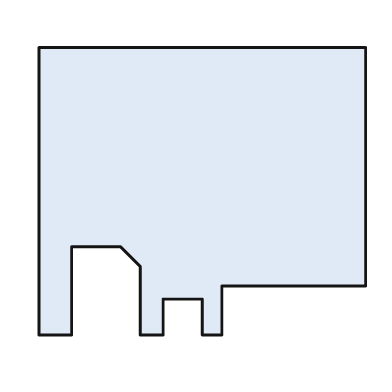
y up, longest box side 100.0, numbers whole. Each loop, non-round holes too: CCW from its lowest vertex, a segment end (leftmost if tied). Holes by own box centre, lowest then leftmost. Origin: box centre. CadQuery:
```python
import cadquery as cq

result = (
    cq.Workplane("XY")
    .moveTo(-50.0, -44.0)
    .lineTo(-40.0, -44.0)
    .lineTo(-40.0, -17.0)
    .lineTo(-25.0, -17.0)
    .lineTo(-19.0, -23.0)
    .lineTo(-19.0, -44.0)
    .lineTo(-12.0, -44.0)
    .lineTo(-12.0, -33.0)
    .lineTo(0.0, -33.0)
    .lineTo(0.0, -44.0)
    .lineTo(6.0, -44.0)
    .lineTo(6.0, -29.0)
    .lineTo(50.0, -29.0)
    .lineTo(50.0, 44.0)
    .lineTo(-50.0, 44.0)
    .close()
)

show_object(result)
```